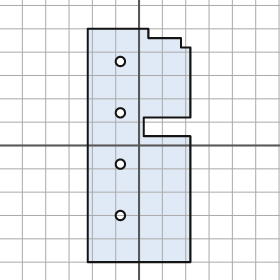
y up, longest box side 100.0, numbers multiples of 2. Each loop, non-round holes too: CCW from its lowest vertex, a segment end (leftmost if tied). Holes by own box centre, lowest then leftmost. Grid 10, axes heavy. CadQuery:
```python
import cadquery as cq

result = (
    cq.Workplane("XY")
    .moveTo(-22.0, -50.0)
    .lineTo(22.0, -50.0)
    .lineTo(22.0, 4.0)
    .lineTo(2.0, 4.0)
    .lineTo(2.0, 12.0)
    .lineTo(22.0, 12.0)
    .lineTo(22.0, 42.0)
    .lineTo(18.0, 42.0)
    .lineTo(18.0, 46.0)
    .lineTo(4.0, 46.0)
    .lineTo(4.0, 50.0)
    .lineTo(-22.0, 50.0)
    .close()
    .moveTo(-8.0, -30.0)
    .circle(2.0)
    .moveTo(-8.0, -8.0)
    .circle(2.0)
    .moveTo(-8.0, 14.0)
    .circle(2.0)
    .moveTo(-8.0, 36.0)
    .circle(2.0)
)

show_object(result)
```